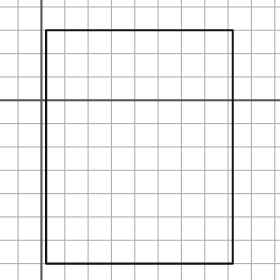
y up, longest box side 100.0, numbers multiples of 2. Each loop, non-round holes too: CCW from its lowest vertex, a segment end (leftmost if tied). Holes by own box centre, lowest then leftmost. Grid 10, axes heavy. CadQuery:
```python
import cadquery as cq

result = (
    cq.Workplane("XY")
    .moveTo(2.0, -70.0)
    .lineTo(82.0, -70.0)
    .lineTo(82.0, 30.0)
    .lineTo(2.0, 30.0)
    .close()
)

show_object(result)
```